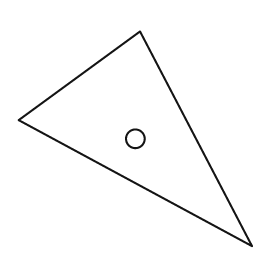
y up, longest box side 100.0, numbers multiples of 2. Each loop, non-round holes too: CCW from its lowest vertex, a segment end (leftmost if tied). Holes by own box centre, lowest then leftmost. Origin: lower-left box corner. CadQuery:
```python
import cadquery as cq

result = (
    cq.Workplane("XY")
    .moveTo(100.0, 0.0)
    .lineTo(52.0, 92.0)
    .lineTo(0.0, 54.0)
    .close()
    .moveTo(50.0, 46.0)
    .circle(4.0)
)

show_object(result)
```